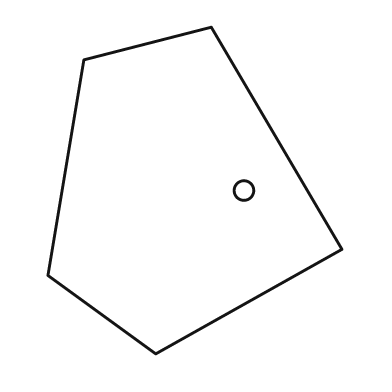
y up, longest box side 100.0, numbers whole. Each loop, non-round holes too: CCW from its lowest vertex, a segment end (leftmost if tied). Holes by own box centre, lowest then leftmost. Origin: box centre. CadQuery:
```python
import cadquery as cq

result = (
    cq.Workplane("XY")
    .moveTo(-12.0, -50.0)
    .lineTo(45.0, -18.0)
    .lineTo(5.0, 50.0)
    .lineTo(-34.0, 40.0)
    .lineTo(-45.0, -26.0)
    .close()
    .moveTo(15.0, 0.0)
    .circle(3.0)
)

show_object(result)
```